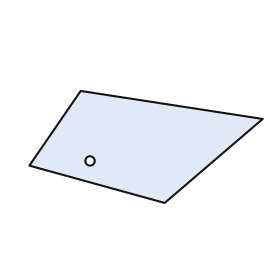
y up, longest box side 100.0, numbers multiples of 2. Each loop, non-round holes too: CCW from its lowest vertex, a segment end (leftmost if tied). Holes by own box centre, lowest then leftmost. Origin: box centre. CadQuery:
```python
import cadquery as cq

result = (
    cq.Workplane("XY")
    .moveTo(8.0, -24.0)
    .lineTo(50.0, 12.0)
    .lineTo(-28.0, 24.0)
    .lineTo(-50.0, -8.0)
    .close()
    .moveTo(-24.0, -6.0)
    .circle(2.0)
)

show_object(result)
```